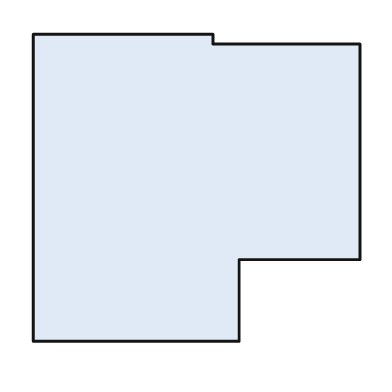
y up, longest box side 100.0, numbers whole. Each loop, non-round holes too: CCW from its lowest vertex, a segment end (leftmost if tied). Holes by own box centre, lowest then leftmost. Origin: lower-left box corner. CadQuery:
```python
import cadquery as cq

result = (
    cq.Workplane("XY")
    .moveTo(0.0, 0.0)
    .lineTo(63.0, 0.0)
    .lineTo(63.0, 25.0)
    .lineTo(100.0, 25.0)
    .lineTo(100.0, 91.0)
    .lineTo(55.0, 91.0)
    .lineTo(55.0, 94.0)
    .lineTo(0.0, 94.0)
    .close()
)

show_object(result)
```